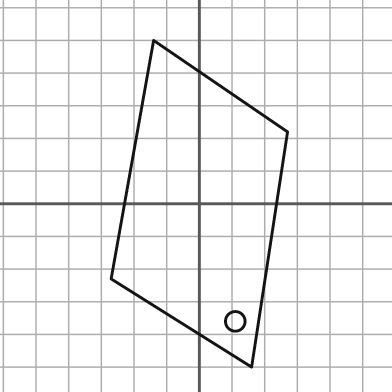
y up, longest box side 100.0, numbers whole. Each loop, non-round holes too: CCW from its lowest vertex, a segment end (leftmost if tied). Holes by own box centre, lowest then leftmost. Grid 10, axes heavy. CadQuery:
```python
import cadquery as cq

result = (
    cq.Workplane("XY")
    .moveTo(16.0, -50.0)
    .lineTo(27.0, 22.0)
    .lineTo(-14.0, 50.0)
    .lineTo(-27.0, -23.0)
    .close()
    .moveTo(11.0, -36.0)
    .circle(3.0)
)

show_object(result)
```